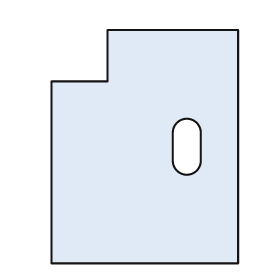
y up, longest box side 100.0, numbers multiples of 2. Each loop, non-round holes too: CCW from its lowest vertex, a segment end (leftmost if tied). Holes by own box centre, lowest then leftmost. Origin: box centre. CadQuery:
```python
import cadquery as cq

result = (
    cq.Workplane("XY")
    .moveTo(-40.0, -50.0)
    .lineTo(40.0, -50.0)
    .lineTo(40.0, 50.0)
    .lineTo(-16.0, 50.0)
    .lineTo(-16.0, 28.0)
    .lineTo(-40.0, 28.0)
    .close()
    .moveTo(12.0, -6.0)
    .threePointArc((18.0, -12.0), (24.0, -6.0))
    .lineTo(24.0, 6.0)
    .threePointArc((18.0, 12.0), (12.0, 6.0))
    .close()
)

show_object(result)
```